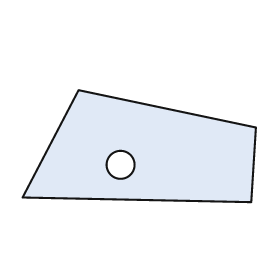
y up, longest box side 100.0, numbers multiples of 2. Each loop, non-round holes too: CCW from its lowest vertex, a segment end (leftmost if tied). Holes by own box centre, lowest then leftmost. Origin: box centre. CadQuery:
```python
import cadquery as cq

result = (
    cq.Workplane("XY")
    .moveTo(48.0, -24.0)
    .lineTo(50.0, 8.0)
    .lineTo(-26.0, 24.0)
    .lineTo(-50.0, -22.0)
    .close()
    .moveTo(-8.0, -8.0)
    .circle(6.0)
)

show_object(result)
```